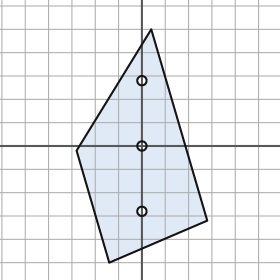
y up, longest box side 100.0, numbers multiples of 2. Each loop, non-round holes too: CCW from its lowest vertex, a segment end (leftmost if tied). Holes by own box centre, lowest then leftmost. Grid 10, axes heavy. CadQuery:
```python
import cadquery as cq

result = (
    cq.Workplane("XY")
    .moveTo(-14.0, -50.0)
    .lineTo(28.0, -32.0)
    .lineTo(4.0, 50.0)
    .lineTo(-28.0, -2.0)
    .close()
    .moveTo(0.0, -28.0)
    .circle(2.0)
    .moveTo(0.0, 0.0)
    .circle(2.0)
    .moveTo(0.0, 28.0)
    .circle(2.0)
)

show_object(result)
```